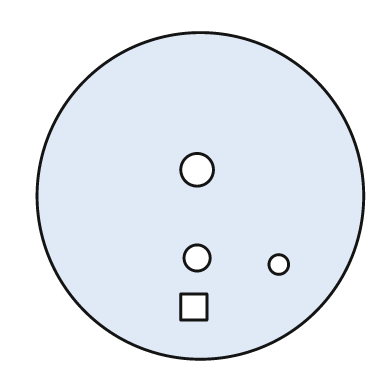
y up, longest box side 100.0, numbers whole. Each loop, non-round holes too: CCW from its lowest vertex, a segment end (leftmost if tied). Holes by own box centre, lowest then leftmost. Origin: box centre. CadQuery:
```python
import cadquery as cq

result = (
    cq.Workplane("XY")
    .moveTo(0.0, 0.0)
    .circle(50.0)
    .moveTo(-6.0, -38.0)
    .lineTo(2.0, -38.0)
    .lineTo(2.0, -30.0)
    .lineTo(-6.0, -30.0)
    .close()
    .moveTo(24.0, -21.0)
    .circle(3.0)
    .moveTo(-1.0, -19.0)
    .circle(4.0)
    .moveTo(-1.0, 8.0)
    .circle(5.0)
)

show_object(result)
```